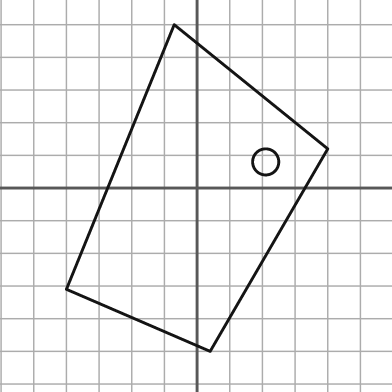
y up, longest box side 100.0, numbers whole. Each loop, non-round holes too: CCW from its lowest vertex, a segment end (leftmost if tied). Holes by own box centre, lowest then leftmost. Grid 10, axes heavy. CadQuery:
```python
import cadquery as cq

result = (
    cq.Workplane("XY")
    .moveTo(4.0, -50.0)
    .lineTo(40.0, 12.0)
    .lineTo(-7.0, 50.0)
    .lineTo(-40.0, -31.0)
    .close()
    .moveTo(21.0, 8.0)
    .circle(4.0)
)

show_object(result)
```